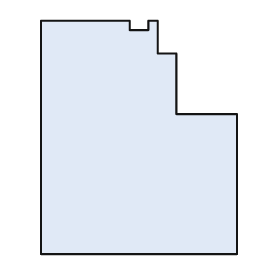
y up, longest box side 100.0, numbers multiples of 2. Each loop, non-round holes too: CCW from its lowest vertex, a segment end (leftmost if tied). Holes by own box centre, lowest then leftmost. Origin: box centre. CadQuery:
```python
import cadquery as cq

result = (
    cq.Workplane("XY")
    .moveTo(-42.0, -50.0)
    .lineTo(42.0, -50.0)
    .lineTo(42.0, 10.0)
    .lineTo(16.0, 10.0)
    .lineTo(16.0, 36.0)
    .lineTo(8.0, 36.0)
    .lineTo(8.0, 50.0)
    .lineTo(4.0, 50.0)
    .lineTo(4.0, 46.0)
    .lineTo(-4.0, 46.0)
    .lineTo(-4.0, 50.0)
    .lineTo(-42.0, 50.0)
    .close()
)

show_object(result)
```